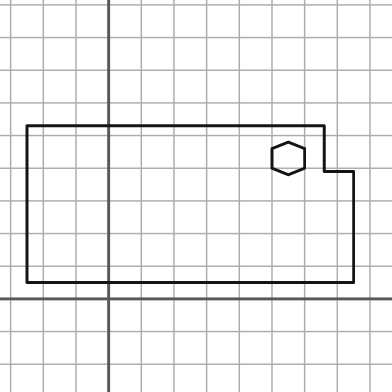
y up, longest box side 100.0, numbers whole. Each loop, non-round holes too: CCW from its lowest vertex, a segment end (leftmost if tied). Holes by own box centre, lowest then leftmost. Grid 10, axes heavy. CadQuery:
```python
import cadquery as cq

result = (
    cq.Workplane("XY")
    .moveTo(-25.0, 5.0)
    .lineTo(75.0, 5.0)
    .lineTo(75.0, 39.0)
    .lineTo(66.0, 39.0)
    .lineTo(66.0, 53.0)
    .lineTo(-25.0, 53.0)
    .close()
    .moveTo(55.0, 38.0)
    .lineTo(60.0, 40.0)
    .lineTo(60.0, 46.0)
    .lineTo(55.0, 48.0)
    .lineTo(50.0, 46.0)
    .lineTo(50.0, 40.0)
    .close()
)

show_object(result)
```